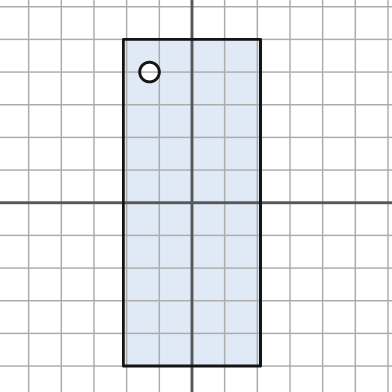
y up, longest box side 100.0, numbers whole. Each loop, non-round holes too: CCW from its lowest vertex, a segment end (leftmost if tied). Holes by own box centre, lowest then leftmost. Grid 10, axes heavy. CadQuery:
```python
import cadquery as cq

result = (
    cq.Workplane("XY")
    .moveTo(-21.0, -50.0)
    .lineTo(21.0, -50.0)
    .lineTo(21.0, 50.0)
    .lineTo(-21.0, 50.0)
    .close()
    .moveTo(-13.0, 40.0)
    .circle(3.0)
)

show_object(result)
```